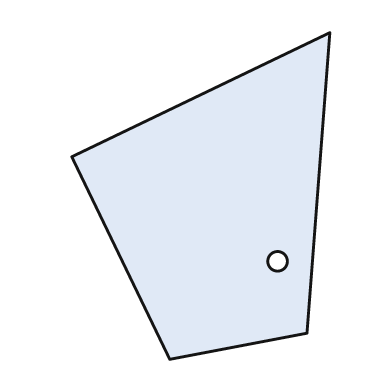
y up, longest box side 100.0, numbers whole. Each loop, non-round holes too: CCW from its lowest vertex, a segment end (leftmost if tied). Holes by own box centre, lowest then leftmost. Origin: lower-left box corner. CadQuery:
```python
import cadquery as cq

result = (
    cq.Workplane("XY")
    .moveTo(30.0, 0.0)
    .lineTo(72.0, 8.0)
    .lineTo(79.0, 100.0)
    .lineTo(0.0, 62.0)
    .close()
    .moveTo(63.0, 30.0)
    .circle(3.0)
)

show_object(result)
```